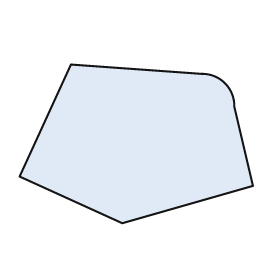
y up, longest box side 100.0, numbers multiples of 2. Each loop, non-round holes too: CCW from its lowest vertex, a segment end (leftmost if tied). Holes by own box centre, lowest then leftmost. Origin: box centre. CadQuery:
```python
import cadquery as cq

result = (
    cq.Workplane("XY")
    .moveTo(-6.0, -34.0)
    .lineTo(50.0, -18.0)
    .lineTo(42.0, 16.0)
    .threePointArc((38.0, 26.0), (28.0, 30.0))
    .lineTo(-28.0, 34.0)
    .lineTo(-50.0, -14.0)
    .close()
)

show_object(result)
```